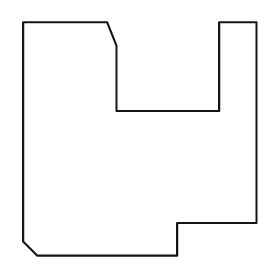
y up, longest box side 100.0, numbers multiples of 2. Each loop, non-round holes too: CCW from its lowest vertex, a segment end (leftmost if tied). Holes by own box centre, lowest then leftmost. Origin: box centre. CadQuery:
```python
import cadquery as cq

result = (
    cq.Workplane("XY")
    .moveTo(-44.0, -50.0)
    .lineTo(16.0, -50.0)
    .lineTo(16.0, -36.0)
    .lineTo(50.0, -36.0)
    .lineTo(50.0, 50.0)
    .lineTo(34.0, 50.0)
    .lineTo(34.0, 12.0)
    .lineTo(-10.0, 12.0)
    .lineTo(-10.0, 40.0)
    .lineTo(-14.0, 50.0)
    .lineTo(-50.0, 50.0)
    .lineTo(-50.0, -44.0)
    .close()
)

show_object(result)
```